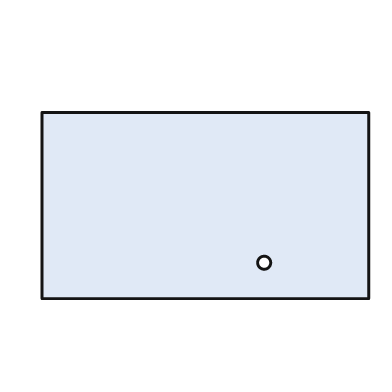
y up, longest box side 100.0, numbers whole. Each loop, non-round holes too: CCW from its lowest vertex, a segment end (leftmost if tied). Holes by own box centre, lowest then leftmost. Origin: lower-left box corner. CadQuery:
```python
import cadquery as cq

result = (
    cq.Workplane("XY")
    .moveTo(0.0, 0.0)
    .lineTo(100.0, 0.0)
    .lineTo(100.0, 57.0)
    .lineTo(0.0, 57.0)
    .close()
    .moveTo(68.0, 11.0)
    .circle(2.0)
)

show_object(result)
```